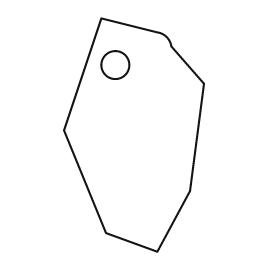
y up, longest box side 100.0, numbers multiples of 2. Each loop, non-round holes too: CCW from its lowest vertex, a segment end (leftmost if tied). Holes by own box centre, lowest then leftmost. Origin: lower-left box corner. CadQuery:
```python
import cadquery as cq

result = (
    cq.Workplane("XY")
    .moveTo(40.0, 0.0)
    .lineTo(54.0, 26.0)
    .lineTo(60.0, 72.0)
    .lineTo(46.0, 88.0)
    .threePointArc((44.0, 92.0), (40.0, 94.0))
    .lineTo(16.0, 100.0)
    .lineTo(0.0, 52.0)
    .lineTo(18.0, 8.0)
    .close()
    .moveTo(22.0, 80.0)
    .circle(6.0)
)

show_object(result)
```